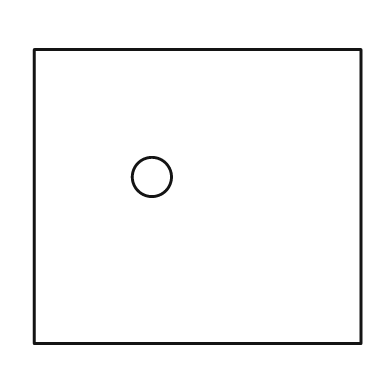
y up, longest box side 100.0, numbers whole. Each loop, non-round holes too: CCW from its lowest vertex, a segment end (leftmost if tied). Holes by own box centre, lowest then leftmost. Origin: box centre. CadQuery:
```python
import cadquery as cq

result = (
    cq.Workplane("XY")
    .moveTo(-50.0, -45.0)
    .lineTo(50.0, -45.0)
    .lineTo(50.0, 45.0)
    .lineTo(-50.0, 45.0)
    .close()
    .moveTo(-14.0, 6.0)
    .circle(6.0)
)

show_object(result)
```